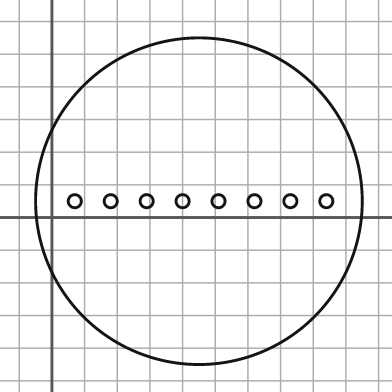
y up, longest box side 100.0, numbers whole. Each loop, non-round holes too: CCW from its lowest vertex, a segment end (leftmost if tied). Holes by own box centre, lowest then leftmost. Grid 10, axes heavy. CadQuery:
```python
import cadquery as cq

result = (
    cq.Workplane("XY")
    .moveTo(45.0, 5.0)
    .circle(50.0)
    .moveTo(7.0, 5.0)
    .circle(2.0)
    .moveTo(18.0, 5.0)
    .circle(2.0)
    .moveTo(29.0, 5.0)
    .circle(2.0)
    .moveTo(40.0, 5.0)
    .circle(2.0)
    .moveTo(51.0, 5.0)
    .circle(2.0)
    .moveTo(62.0, 5.0)
    .circle(2.0)
    .moveTo(73.0, 5.0)
    .circle(2.0)
    .moveTo(84.0, 5.0)
    .circle(2.0)
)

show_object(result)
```